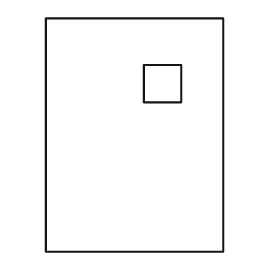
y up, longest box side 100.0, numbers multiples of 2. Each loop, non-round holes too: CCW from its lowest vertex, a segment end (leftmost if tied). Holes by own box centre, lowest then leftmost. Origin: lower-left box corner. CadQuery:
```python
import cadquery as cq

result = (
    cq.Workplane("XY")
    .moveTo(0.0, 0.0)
    .lineTo(76.0, 0.0)
    .lineTo(76.0, 100.0)
    .lineTo(0.0, 100.0)
    .close()
    .moveTo(42.0, 64.0)
    .lineTo(58.0, 64.0)
    .lineTo(58.0, 80.0)
    .lineTo(42.0, 80.0)
    .close()
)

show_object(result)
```